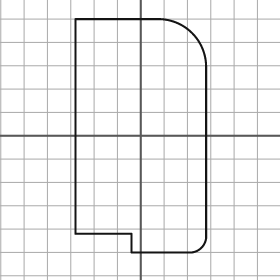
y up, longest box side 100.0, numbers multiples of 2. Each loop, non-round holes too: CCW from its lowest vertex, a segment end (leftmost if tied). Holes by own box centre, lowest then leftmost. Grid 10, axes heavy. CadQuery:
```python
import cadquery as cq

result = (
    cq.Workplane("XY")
    .moveTo(-4.0, -50.0)
    .lineTo(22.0, -50.0)
    .threePointArc((26.0, -48.0), (28.0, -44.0))
    .lineTo(28.0, 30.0)
    .threePointArc((22.0, 44.0), (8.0, 50.0))
    .lineTo(-28.0, 50.0)
    .lineTo(-28.0, -42.0)
    .lineTo(-4.0, -42.0)
    .close()
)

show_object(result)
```